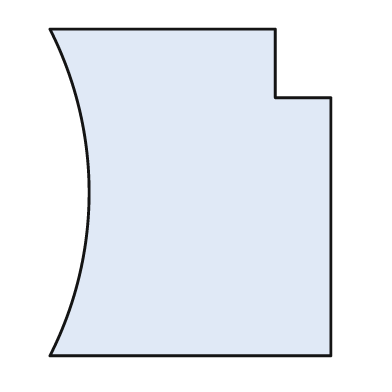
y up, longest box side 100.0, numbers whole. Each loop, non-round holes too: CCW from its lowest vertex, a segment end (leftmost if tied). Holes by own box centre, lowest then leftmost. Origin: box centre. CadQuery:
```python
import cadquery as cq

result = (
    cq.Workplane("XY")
    .moveTo(-43.0, -50.0)
    .lineTo(43.0, -50.0)
    .lineTo(43.0, 29.0)
    .lineTo(26.0, 29.0)
    .lineTo(26.0, 50.0)
    .lineTo(-43.0, 50.0)
    .threePointArc((-31.0, 0.0), (-43.0, -50.0))
    .close()
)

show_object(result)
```